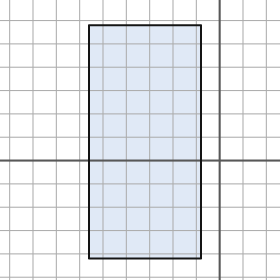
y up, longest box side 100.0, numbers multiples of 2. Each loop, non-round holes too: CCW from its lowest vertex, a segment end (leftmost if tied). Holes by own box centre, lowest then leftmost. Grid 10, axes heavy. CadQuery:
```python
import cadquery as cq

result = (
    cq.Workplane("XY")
    .moveTo(-56.0, -42.0)
    .lineTo(-8.0, -42.0)
    .lineTo(-8.0, 58.0)
    .lineTo(-56.0, 58.0)
    .close()
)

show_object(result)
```